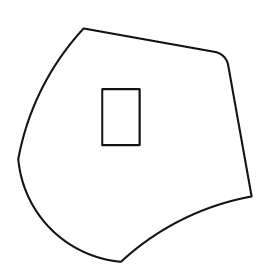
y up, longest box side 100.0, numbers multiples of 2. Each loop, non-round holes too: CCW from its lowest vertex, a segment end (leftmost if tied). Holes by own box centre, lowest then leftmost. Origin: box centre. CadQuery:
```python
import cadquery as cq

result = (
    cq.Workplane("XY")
    .moveTo(-6.0, -50.0)
    .threePointArc((20.0, -32.0), (50.0, -22.0))
    .lineTo(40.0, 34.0)
    .threePointArc((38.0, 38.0), (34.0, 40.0))
    .lineTo(-22.0, 50.0)
    .threePointArc((-40.0, 24.0), (-50.0, -6.0))
    .threePointArc((-36.0, -36.0), (-6.0, -50.0))
    .close()
    .moveTo(-14.0, 0.0)
    .lineTo(2.0, 0.0)
    .lineTo(2.0, 24.0)
    .lineTo(-14.0, 24.0)
    .close()
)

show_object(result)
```